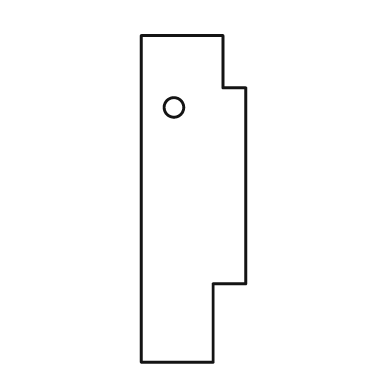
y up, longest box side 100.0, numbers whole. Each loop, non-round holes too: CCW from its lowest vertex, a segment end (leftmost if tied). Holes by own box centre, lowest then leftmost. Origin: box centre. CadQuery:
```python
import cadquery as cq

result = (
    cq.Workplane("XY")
    .moveTo(-16.0, -50.0)
    .lineTo(6.0, -50.0)
    .lineTo(6.0, -26.0)
    .lineTo(16.0, -26.0)
    .lineTo(16.0, 34.0)
    .lineTo(9.0, 34.0)
    .lineTo(9.0, 50.0)
    .lineTo(-16.0, 50.0)
    .close()
    .moveTo(-6.0, 28.0)
    .circle(3.0)
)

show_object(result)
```